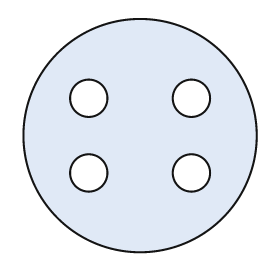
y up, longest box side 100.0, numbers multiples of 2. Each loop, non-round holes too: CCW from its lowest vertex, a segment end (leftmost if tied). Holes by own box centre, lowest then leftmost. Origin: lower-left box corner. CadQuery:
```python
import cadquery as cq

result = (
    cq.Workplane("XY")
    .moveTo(50.0, 50.0)
    .circle(50.0)
    .moveTo(28.0, 34.0)
    .circle(8.0)
    .moveTo(72.0, 34.0)
    .circle(8.0)
    .moveTo(28.0, 66.0)
    .circle(8.0)
    .moveTo(72.0, 66.0)
    .circle(8.0)
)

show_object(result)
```